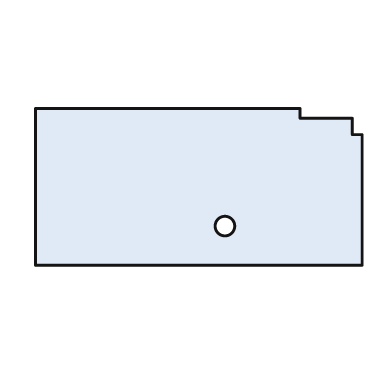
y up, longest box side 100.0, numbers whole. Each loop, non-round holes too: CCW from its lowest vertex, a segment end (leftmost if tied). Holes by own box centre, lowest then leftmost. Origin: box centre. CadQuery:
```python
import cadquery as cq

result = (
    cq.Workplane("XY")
    .moveTo(-50.0, -24.0)
    .lineTo(50.0, -24.0)
    .lineTo(50.0, 16.0)
    .lineTo(47.0, 16.0)
    .lineTo(47.0, 21.0)
    .lineTo(31.0, 21.0)
    .lineTo(31.0, 24.0)
    .lineTo(-50.0, 24.0)
    .close()
    .moveTo(8.0, -12.0)
    .circle(3.0)
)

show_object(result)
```